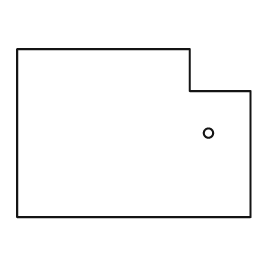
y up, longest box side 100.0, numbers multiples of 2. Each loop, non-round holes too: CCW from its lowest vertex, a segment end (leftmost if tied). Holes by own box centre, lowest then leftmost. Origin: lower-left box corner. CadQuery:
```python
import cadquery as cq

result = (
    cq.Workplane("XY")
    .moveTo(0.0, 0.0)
    .lineTo(100.0, 0.0)
    .lineTo(100.0, 54.0)
    .lineTo(74.0, 54.0)
    .lineTo(74.0, 72.0)
    .lineTo(0.0, 72.0)
    .close()
    .moveTo(82.0, 36.0)
    .circle(2.0)
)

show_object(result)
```